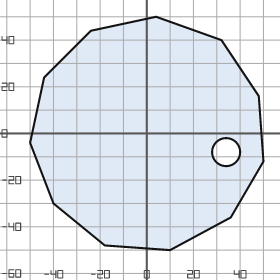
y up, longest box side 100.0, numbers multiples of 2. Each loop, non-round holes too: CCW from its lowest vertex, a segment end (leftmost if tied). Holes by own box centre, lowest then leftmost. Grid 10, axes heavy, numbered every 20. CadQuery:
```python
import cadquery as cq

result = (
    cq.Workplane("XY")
    .moveTo(10.0, -50.0)
    .lineTo(36.0, -36.0)
    .lineTo(50.0, -12.0)
    .lineTo(48.0, 16.0)
    .lineTo(32.0, 40.0)
    .lineTo(4.0, 50.0)
    .lineTo(-24.0, 44.0)
    .lineTo(-44.0, 24.0)
    .lineTo(-50.0, -4.0)
    .lineTo(-40.0, -30.0)
    .lineTo(-18.0, -48.0)
    .close()
    .moveTo(34.0, -8.0)
    .circle(6.0)
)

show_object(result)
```